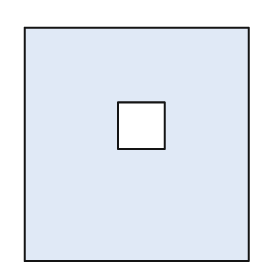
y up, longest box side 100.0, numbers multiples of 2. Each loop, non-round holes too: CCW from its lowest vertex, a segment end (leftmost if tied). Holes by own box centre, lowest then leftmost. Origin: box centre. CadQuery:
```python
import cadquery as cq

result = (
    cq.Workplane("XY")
    .moveTo(-48.0, -50.0)
    .lineTo(48.0, -50.0)
    .lineTo(48.0, 50.0)
    .lineTo(-48.0, 50.0)
    .close()
    .moveTo(-8.0, -2.0)
    .lineTo(12.0, -2.0)
    .lineTo(12.0, 18.0)
    .lineTo(-8.0, 18.0)
    .close()
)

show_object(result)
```